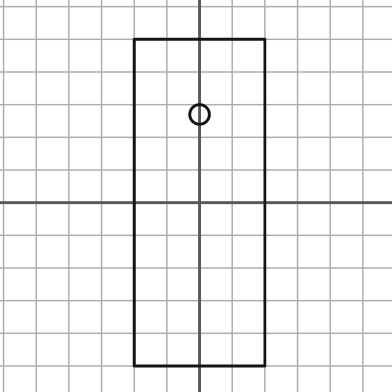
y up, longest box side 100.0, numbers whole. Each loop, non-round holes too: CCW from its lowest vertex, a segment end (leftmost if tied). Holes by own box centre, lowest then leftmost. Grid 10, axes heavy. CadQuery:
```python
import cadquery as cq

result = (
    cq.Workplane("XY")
    .moveTo(-20.0, -50.0)
    .lineTo(20.0, -50.0)
    .lineTo(20.0, 50.0)
    .lineTo(-20.0, 50.0)
    .close()
    .moveTo(0.0, 27.0)
    .circle(3.0)
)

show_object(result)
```